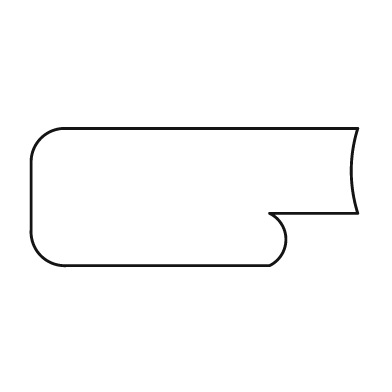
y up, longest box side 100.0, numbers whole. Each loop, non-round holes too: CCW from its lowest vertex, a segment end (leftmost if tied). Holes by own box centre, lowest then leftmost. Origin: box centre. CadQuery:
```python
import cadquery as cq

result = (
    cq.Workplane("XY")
    .moveTo(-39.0, -21.0)
    .lineTo(23.0, -21.0)
    .threePointArc((28.0, -13.0), (23.0, -5.0))
    .lineTo(50.0, -5.0)
    .threePointArc((48.0, 8.0), (50.0, 21.0))
    .lineTo(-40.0, 21.0)
    .threePointArc((-47.0, 18.0), (-50.0, 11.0))
    .lineTo(-50.0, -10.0)
    .threePointArc((-47.0, -18.0), (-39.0, -21.0))
    .close()
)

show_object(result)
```